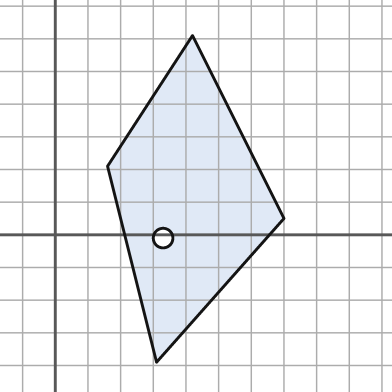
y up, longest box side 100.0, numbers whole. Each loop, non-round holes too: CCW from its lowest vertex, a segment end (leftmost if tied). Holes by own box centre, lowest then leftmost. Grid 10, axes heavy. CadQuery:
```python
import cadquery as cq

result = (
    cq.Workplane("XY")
    .moveTo(31.0, -39.0)
    .lineTo(70.0, 5.0)
    .lineTo(42.0, 61.0)
    .lineTo(16.0, 21.0)
    .close()
    .moveTo(33.0, -1.0)
    .circle(3.0)
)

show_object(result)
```